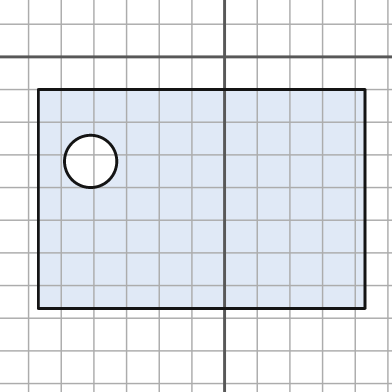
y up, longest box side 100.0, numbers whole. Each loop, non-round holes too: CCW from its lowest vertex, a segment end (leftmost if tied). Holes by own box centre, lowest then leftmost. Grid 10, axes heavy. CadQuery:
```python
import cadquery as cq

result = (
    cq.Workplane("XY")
    .moveTo(-57.0, -77.0)
    .lineTo(43.0, -77.0)
    .lineTo(43.0, -10.0)
    .lineTo(-57.0, -10.0)
    .close()
    .moveTo(-41.0, -32.0)
    .circle(8.0)
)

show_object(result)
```